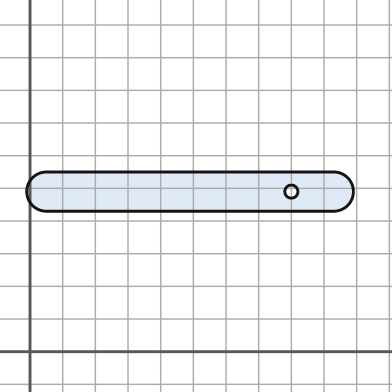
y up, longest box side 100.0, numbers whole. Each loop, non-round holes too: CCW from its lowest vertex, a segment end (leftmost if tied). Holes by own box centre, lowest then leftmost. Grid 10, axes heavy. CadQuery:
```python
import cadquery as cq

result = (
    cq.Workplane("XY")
    .moveTo(5.0, 43.0)
    .lineTo(93.0, 43.0)
    .threePointArc((99.0, 49.0), (93.0, 55.0))
    .lineTo(5.0, 55.0)
    .threePointArc((-1.0, 49.0), (5.0, 43.0))
    .close()
    .moveTo(80.0, 49.0)
    .circle(2.0)
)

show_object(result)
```